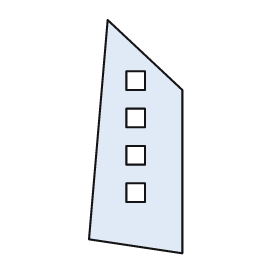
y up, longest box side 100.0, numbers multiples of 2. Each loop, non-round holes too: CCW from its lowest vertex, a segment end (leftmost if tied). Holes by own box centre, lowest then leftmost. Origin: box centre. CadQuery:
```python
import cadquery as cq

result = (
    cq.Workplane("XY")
    .moveTo(20.0, -50.0)
    .lineTo(20.0, 20.0)
    .lineTo(-12.0, 50.0)
    .lineTo(-20.0, -44.0)
    .close()
    .moveTo(-4.0, -28.0)
    .lineTo(4.0, -28.0)
    .lineTo(4.0, -20.0)
    .lineTo(-4.0, -20.0)
    .close()
    .moveTo(-4.0, -12.0)
    .lineTo(4.0, -12.0)
    .lineTo(4.0, -4.0)
    .lineTo(-4.0, -4.0)
    .close()
    .moveTo(-4.0, 4.0)
    .lineTo(4.0, 4.0)
    .lineTo(4.0, 12.0)
    .lineTo(-4.0, 12.0)
    .close()
    .moveTo(-4.0, 20.0)
    .lineTo(4.0, 20.0)
    .lineTo(4.0, 28.0)
    .lineTo(-4.0, 28.0)
    .close()
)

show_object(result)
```